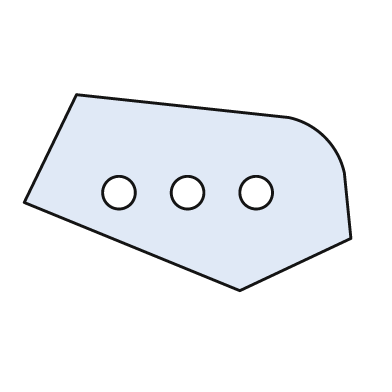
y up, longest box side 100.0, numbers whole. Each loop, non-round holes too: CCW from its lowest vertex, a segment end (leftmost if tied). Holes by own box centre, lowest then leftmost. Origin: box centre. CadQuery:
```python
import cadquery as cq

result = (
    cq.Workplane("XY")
    .moveTo(16.0, -30.0)
    .lineTo(50.0, -14.0)
    .lineTo(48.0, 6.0)
    .threePointArc((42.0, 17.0), (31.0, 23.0))
    .lineTo(-34.0, 30.0)
    .lineTo(-50.0, -3.0)
    .close()
    .moveTo(-21.0, 0.0)
    .circle(5.0)
    .moveTo(0.0, 0.0)
    .circle(5.0)
    .moveTo(21.0, 0.0)
    .circle(5.0)
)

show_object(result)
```